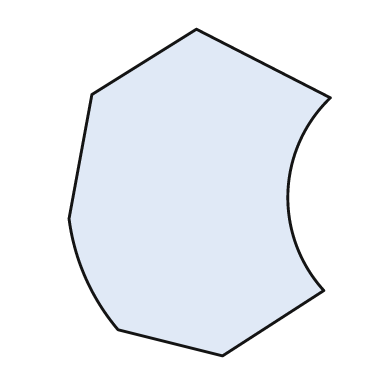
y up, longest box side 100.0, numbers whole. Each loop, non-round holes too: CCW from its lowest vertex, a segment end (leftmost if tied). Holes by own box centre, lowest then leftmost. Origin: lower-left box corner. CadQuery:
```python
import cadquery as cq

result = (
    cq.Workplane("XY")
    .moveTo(47.0, 0.0)
    .lineTo(78.0, 20.0)
    .threePointArc((67.0, 50.0), (80.0, 79.0))
    .lineTo(39.0, 100.0)
    .lineTo(7.0, 80.0)
    .lineTo(0.0, 42.0)
    .threePointArc((5.0, 24.0), (15.0, 8.0))
    .close()
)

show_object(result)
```